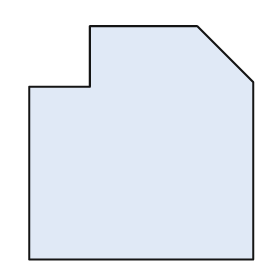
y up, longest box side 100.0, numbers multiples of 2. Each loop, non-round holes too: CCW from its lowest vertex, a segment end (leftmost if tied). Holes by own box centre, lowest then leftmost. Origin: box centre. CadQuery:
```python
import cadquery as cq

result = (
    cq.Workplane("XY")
    .moveTo(-48.0, -50.0)
    .lineTo(48.0, -50.0)
    .lineTo(48.0, 26.0)
    .lineTo(24.0, 50.0)
    .lineTo(-22.0, 50.0)
    .lineTo(-22.0, 24.0)
    .lineTo(-48.0, 24.0)
    .close()
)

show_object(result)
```